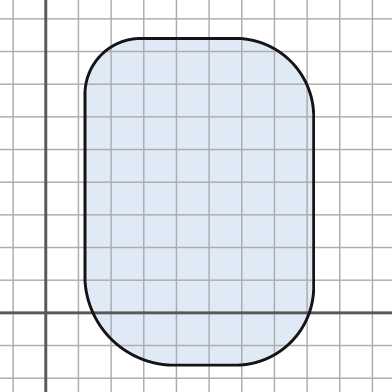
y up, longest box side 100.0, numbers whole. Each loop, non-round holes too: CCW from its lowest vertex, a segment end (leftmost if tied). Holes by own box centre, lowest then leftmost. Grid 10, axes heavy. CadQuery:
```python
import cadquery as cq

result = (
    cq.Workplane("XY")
    .moveTo(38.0, -16.0)
    .lineTo(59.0, -16.0)
    .threePointArc((75.0, -9.0), (82.0, 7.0))
    .lineTo(82.0, 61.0)
    .threePointArc((75.0, 77.0), (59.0, 84.0))
    .lineTo(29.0, 84.0)
    .threePointArc((17.0, 79.0), (12.0, 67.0))
    .lineTo(12.0, 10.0)
    .threePointArc((20.0, -8.0), (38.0, -16.0))
    .close()
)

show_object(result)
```